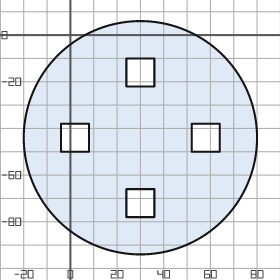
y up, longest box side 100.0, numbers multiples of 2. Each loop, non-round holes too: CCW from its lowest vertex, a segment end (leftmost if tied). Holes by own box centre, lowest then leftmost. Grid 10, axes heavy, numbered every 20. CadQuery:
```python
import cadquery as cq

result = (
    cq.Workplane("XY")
    .moveTo(30.0, -44.0)
    .circle(50.0)
    .moveTo(24.0, -78.0)
    .lineTo(36.0, -78.0)
    .lineTo(36.0, -66.0)
    .lineTo(24.0, -66.0)
    .close()
    .moveTo(-4.0, -50.0)
    .lineTo(8.0, -50.0)
    .lineTo(8.0, -38.0)
    .lineTo(-4.0, -38.0)
    .close()
    .moveTo(52.0, -50.0)
    .lineTo(64.0, -50.0)
    .lineTo(64.0, -38.0)
    .lineTo(52.0, -38.0)
    .close()
    .moveTo(24.0, -22.0)
    .lineTo(36.0, -22.0)
    .lineTo(36.0, -10.0)
    .lineTo(24.0, -10.0)
    .close()
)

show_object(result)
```